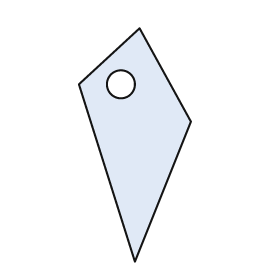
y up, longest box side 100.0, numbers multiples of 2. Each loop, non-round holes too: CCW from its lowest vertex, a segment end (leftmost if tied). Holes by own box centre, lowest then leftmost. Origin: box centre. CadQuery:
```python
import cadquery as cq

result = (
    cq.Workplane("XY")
    .moveTo(0.0, -50.0)
    .lineTo(24.0, 10.0)
    .lineTo(2.0, 50.0)
    .lineTo(-24.0, 26.0)
    .close()
    .moveTo(-6.0, 26.0)
    .circle(6.0)
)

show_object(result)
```